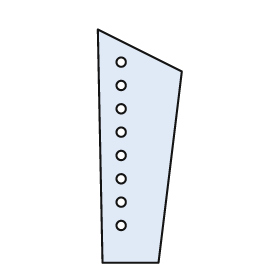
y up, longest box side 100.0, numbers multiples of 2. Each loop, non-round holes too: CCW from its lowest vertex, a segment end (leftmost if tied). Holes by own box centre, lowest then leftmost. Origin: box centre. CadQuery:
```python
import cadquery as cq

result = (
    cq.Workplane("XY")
    .moveTo(-16.0, -50.0)
    .lineTo(8.0, -50.0)
    .lineTo(18.0, 32.0)
    .lineTo(-18.0, 50.0)
    .close()
    .moveTo(-8.0, -34.0)
    .circle(2.0)
    .moveTo(-8.0, -24.0)
    .circle(2.0)
    .moveTo(-8.0, -14.0)
    .circle(2.0)
    .moveTo(-8.0, -4.0)
    .circle(2.0)
    .moveTo(-8.0, 6.0)
    .circle(2.0)
    .moveTo(-8.0, 16.0)
    .circle(2.0)
    .moveTo(-8.0, 26.0)
    .circle(2.0)
    .moveTo(-8.0, 36.0)
    .circle(2.0)
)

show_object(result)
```